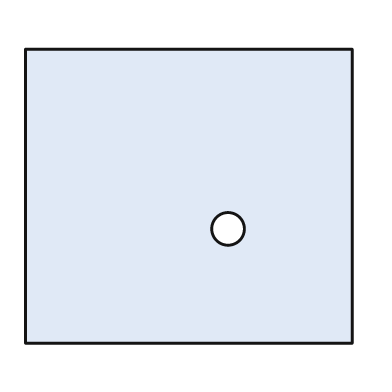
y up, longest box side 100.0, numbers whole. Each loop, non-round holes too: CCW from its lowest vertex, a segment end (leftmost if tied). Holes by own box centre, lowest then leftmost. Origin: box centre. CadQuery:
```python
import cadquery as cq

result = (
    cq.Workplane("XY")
    .moveTo(-50.0, -45.0)
    .lineTo(50.0, -45.0)
    .lineTo(50.0, 45.0)
    .lineTo(-50.0, 45.0)
    .close()
    .moveTo(12.0, -10.0)
    .circle(5.0)
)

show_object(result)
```